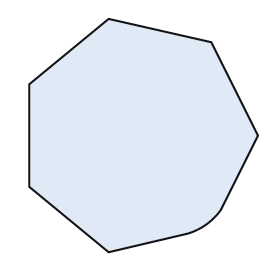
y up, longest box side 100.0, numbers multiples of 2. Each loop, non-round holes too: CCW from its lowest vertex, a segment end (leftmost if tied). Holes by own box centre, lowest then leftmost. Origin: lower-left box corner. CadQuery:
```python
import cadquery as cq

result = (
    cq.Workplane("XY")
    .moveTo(34.0, 0.0)
    .lineTo(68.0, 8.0)
    .threePointArc((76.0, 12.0), (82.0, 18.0))
    .lineTo(98.0, 50.0)
    .lineTo(78.0, 90.0)
    .lineTo(34.0, 100.0)
    .lineTo(0.0, 72.0)
    .lineTo(0.0, 28.0)
    .close()
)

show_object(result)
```